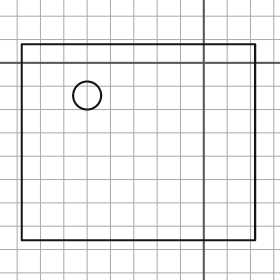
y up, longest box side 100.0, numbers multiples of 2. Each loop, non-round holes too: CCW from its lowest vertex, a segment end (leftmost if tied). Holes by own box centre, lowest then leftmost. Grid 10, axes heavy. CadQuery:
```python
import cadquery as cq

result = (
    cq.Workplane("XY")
    .moveTo(-78.0, -76.0)
    .lineTo(22.0, -76.0)
    .lineTo(22.0, 8.0)
    .lineTo(-78.0, 8.0)
    .close()
    .moveTo(-50.0, -14.0)
    .circle(6.0)
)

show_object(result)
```